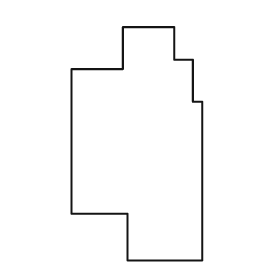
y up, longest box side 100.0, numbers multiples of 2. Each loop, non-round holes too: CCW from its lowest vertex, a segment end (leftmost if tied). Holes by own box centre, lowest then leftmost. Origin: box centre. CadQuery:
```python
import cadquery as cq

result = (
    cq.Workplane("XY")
    .moveTo(-4.0, -50.0)
    .lineTo(28.0, -50.0)
    .lineTo(28.0, 18.0)
    .lineTo(24.0, 18.0)
    .lineTo(24.0, 36.0)
    .lineTo(16.0, 36.0)
    .lineTo(16.0, 50.0)
    .lineTo(-6.0, 50.0)
    .lineTo(-6.0, 32.0)
    .lineTo(-28.0, 32.0)
    .lineTo(-28.0, -30.0)
    .lineTo(-4.0, -30.0)
    .close()
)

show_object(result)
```